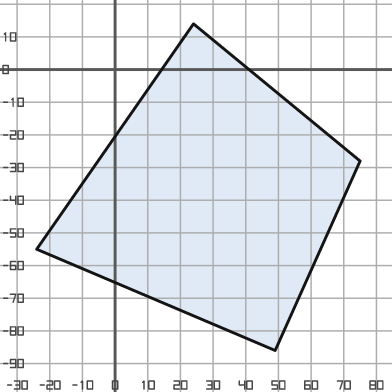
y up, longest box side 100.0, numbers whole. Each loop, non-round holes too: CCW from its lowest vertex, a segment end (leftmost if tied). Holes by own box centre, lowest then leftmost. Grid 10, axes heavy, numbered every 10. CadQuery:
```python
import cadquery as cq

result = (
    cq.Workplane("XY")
    .moveTo(49.0, -86.0)
    .lineTo(75.0, -28.0)
    .lineTo(24.0, 14.0)
    .lineTo(-24.0, -55.0)
    .close()
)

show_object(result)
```